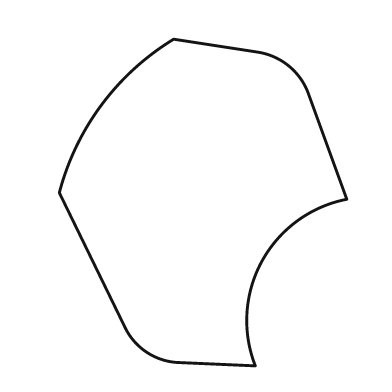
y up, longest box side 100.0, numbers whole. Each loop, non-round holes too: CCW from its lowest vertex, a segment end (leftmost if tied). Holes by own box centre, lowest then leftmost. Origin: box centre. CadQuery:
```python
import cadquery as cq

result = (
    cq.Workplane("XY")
    .moveTo(16.0, -50.0)
    .threePointArc((18.0, -18.0), (44.0, 1.0))
    .lineTo(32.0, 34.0)
    .threePointArc((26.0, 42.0), (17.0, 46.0))
    .lineTo(-9.0, 50.0)
    .threePointArc((-31.0, 30.0), (-44.0, 3.0))
    .lineTo(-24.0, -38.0)
    .threePointArc((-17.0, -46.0), (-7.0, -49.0))
    .close()
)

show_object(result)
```